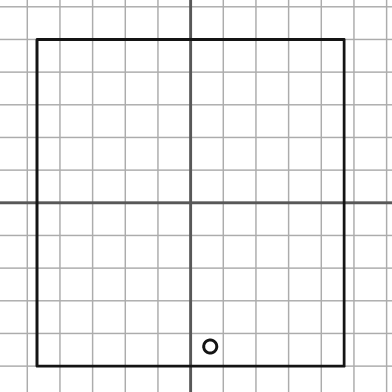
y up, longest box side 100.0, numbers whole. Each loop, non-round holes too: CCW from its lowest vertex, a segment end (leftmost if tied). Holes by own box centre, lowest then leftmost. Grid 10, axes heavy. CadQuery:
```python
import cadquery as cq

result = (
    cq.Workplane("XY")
    .moveTo(-47.0, -50.0)
    .lineTo(47.0, -50.0)
    .lineTo(47.0, 50.0)
    .lineTo(-47.0, 50.0)
    .close()
    .moveTo(6.0, -44.0)
    .circle(2.0)
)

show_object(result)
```